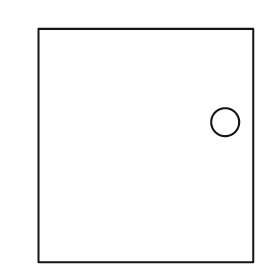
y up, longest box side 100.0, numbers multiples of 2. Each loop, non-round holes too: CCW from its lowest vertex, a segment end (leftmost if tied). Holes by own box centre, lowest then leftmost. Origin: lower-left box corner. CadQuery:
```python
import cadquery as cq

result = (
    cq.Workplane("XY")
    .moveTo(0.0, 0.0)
    .lineTo(92.0, 0.0)
    .lineTo(92.0, 100.0)
    .lineTo(0.0, 100.0)
    .close()
    .moveTo(80.0, 60.0)
    .circle(6.0)
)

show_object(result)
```